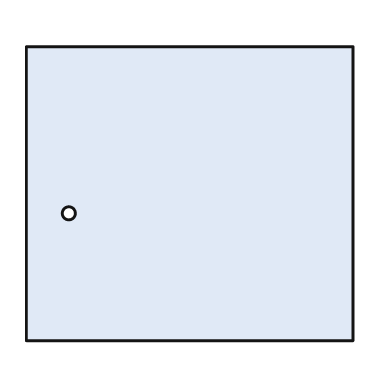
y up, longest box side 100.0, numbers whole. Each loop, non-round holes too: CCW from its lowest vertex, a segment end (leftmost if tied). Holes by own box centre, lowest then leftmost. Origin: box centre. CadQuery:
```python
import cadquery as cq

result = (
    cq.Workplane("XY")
    .moveTo(-50.0, -45.0)
    .lineTo(50.0, -45.0)
    .lineTo(50.0, 45.0)
    .lineTo(-50.0, 45.0)
    .close()
    .moveTo(-37.0, -6.0)
    .circle(2.0)
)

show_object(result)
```